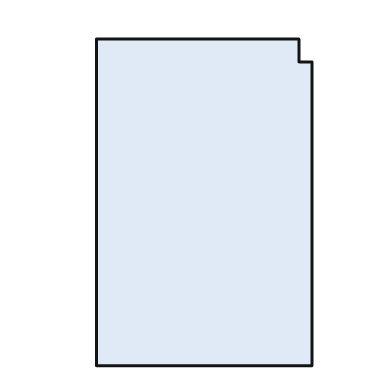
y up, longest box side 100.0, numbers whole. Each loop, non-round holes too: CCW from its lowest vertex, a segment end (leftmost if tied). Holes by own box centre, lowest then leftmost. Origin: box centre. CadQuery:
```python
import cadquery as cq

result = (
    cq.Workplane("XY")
    .moveTo(-33.0, -50.0)
    .lineTo(33.0, -50.0)
    .lineTo(33.0, 43.0)
    .lineTo(29.0, 43.0)
    .lineTo(29.0, 50.0)
    .lineTo(-33.0, 50.0)
    .close()
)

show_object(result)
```